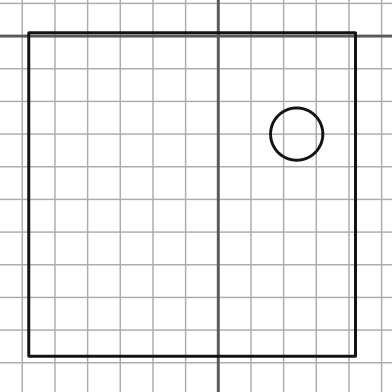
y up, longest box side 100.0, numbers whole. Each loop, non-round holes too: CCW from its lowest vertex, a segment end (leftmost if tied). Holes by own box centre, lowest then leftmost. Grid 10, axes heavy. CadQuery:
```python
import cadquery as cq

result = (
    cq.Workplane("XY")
    .moveTo(-58.0, -98.0)
    .lineTo(42.0, -98.0)
    .lineTo(42.0, 1.0)
    .lineTo(-58.0, 1.0)
    .close()
    .moveTo(24.0, -30.0)
    .circle(8.0)
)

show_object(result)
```